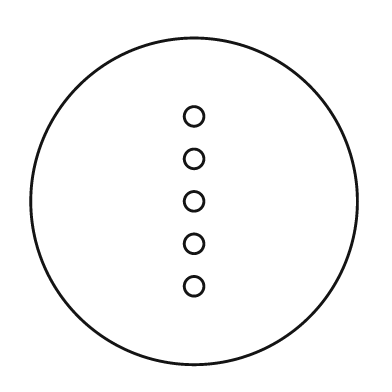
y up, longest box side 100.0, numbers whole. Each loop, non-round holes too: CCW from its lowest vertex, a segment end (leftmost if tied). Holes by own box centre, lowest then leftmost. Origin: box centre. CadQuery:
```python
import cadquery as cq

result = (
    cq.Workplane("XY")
    .moveTo(0.0, 0.0)
    .circle(50.0)
    .moveTo(0.0, -26.0)
    .circle(3.0)
    .moveTo(0.0, -13.0)
    .circle(3.0)
    .moveTo(0.0, 0.0)
    .circle(3.0)
    .moveTo(0.0, 13.0)
    .circle(3.0)
    .moveTo(0.0, 26.0)
    .circle(3.0)
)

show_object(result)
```